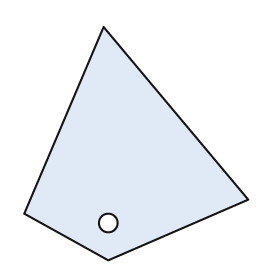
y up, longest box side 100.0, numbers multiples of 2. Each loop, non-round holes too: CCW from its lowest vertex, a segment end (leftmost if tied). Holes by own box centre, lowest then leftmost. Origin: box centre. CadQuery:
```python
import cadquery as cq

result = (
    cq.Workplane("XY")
    .moveTo(-12.0, -50.0)
    .lineTo(48.0, -24.0)
    .lineTo(-14.0, 50.0)
    .lineTo(-48.0, -30.0)
    .close()
    .moveTo(-12.0, -34.0)
    .circle(4.0)
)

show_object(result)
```